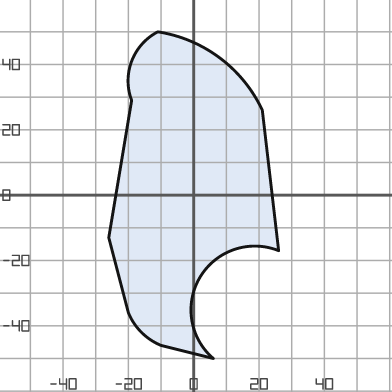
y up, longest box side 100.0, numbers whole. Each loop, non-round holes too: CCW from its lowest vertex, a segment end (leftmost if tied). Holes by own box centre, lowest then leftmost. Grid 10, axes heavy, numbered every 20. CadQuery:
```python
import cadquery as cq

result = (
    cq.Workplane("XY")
    .moveTo(6.0, -50.0)
    .threePointArc((2.0, -25.0), (26.0, -17.0))
    .lineTo(21.0, 26.0)
    .threePointArc((8.0, 42.0), (-11.0, 50.0))
    .threePointArc((-19.0, 41.0), (-19.0, 29.0))
    .lineTo(-26.0, -13.0)
    .lineTo(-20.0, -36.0)
    .threePointArc((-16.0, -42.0), (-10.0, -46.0))
    .close()
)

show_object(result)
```